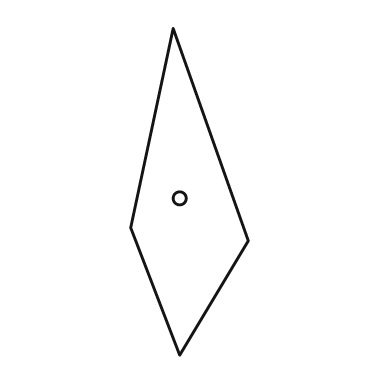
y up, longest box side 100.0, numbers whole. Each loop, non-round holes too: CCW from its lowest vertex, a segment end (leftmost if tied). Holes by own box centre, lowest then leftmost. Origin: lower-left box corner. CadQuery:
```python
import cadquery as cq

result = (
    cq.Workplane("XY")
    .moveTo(15.0, 0.0)
    .lineTo(36.0, 35.0)
    .lineTo(13.0, 100.0)
    .lineTo(0.0, 39.0)
    .close()
    .moveTo(15.0, 48.0)
    .circle(2.0)
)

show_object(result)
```